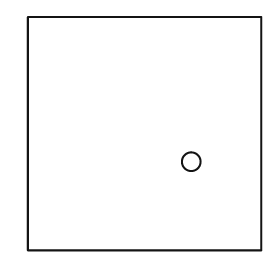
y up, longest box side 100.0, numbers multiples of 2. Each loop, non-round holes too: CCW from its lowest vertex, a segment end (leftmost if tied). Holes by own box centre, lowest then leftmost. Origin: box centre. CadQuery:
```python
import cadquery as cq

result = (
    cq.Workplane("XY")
    .moveTo(-50.0, -50.0)
    .lineTo(50.0, -50.0)
    .lineTo(50.0, 50.0)
    .lineTo(-50.0, 50.0)
    .close()
    .moveTo(20.0, -12.0)
    .circle(4.0)
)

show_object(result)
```